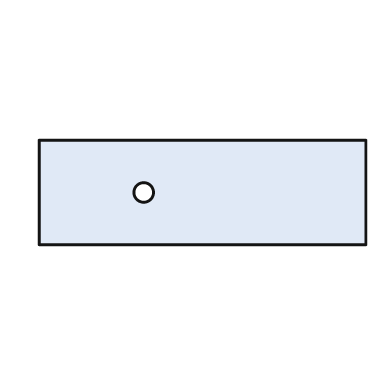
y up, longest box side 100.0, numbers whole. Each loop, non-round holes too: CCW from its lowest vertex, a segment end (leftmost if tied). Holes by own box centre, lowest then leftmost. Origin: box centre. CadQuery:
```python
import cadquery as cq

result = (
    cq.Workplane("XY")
    .moveTo(-50.0, -16.0)
    .lineTo(50.0, -16.0)
    .lineTo(50.0, 16.0)
    .lineTo(-50.0, 16.0)
    .close()
    .moveTo(-18.0, 0.0)
    .circle(3.0)
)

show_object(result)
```